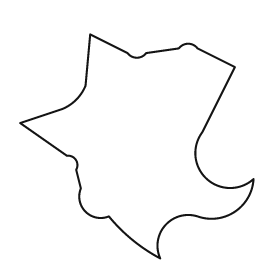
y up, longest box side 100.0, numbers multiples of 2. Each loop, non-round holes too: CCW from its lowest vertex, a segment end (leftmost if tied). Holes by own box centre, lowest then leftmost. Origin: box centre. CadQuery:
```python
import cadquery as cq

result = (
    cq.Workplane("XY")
    .moveTo(10.0, -48.0)
    .threePointArc((12.0, -34.0), (26.0, -30.0))
    .threePointArc((42.0, -28.0), (50.0, -14.0))
    .threePointArc((30.0, -14.0), (28.0, 6.0))
    .lineTo(42.0, 34.0)
    .lineTo(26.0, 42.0)
    .threePointArc((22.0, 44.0), (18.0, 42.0))
    .lineTo(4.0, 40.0)
    .threePointArc((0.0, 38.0), (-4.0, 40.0))
    .lineTo(-20.0, 48.0)
    .lineTo(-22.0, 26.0)
    .threePointArc((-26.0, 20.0), (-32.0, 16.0))
    .lineTo(-50.0, 10.0)
    .lineTo(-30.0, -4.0)
    .threePointArc((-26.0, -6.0), (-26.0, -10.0))
    .lineTo(-24.0, -18.0)
    .threePointArc((-22.0, -28.0), (-12.0, -30.0))
    .threePointArc((-2.0, -40.0), (10.0, -48.0))
    .close()
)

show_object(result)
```